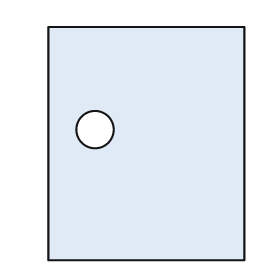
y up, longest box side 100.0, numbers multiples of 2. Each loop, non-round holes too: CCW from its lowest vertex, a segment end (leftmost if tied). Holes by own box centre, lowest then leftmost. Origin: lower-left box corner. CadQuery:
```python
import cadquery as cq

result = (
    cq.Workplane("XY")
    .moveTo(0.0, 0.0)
    .lineTo(84.0, 0.0)
    .lineTo(84.0, 100.0)
    .lineTo(0.0, 100.0)
    .close()
    .moveTo(20.0, 56.0)
    .circle(8.0)
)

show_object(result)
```